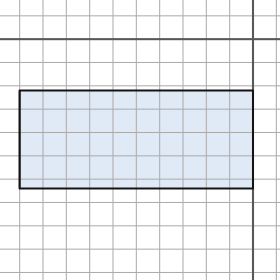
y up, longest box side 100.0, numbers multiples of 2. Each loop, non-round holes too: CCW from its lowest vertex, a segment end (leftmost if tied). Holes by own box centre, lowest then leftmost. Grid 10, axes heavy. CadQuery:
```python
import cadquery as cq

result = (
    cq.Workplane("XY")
    .moveTo(-100.0, -64.0)
    .lineTo(0.0, -64.0)
    .lineTo(0.0, -22.0)
    .lineTo(-100.0, -22.0)
    .close()
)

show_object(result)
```